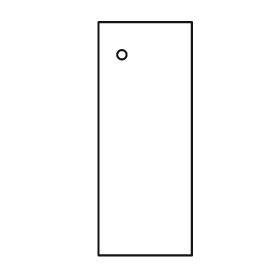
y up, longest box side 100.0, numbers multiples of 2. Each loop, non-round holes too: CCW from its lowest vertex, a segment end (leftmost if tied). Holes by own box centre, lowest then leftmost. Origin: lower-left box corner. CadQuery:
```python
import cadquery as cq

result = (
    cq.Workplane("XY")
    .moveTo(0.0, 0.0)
    .lineTo(40.0, 0.0)
    .lineTo(40.0, 100.0)
    .lineTo(0.0, 100.0)
    .close()
    .moveTo(10.0, 86.0)
    .circle(2.0)
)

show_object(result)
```